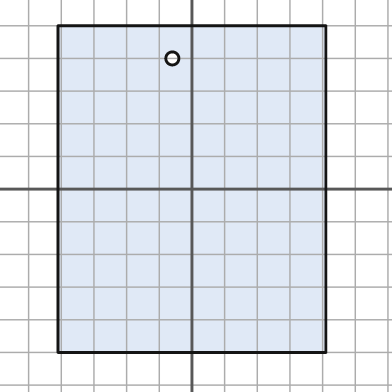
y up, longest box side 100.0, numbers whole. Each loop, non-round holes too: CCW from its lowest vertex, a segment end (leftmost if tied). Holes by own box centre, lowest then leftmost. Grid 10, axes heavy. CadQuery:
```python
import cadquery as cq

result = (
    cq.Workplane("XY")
    .moveTo(-41.0, -50.0)
    .lineTo(41.0, -50.0)
    .lineTo(41.0, 50.0)
    .lineTo(-41.0, 50.0)
    .close()
    .moveTo(-6.0, 40.0)
    .circle(2.0)
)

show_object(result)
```